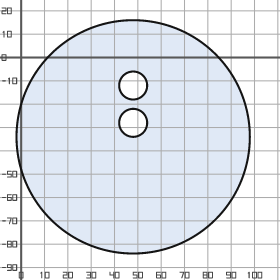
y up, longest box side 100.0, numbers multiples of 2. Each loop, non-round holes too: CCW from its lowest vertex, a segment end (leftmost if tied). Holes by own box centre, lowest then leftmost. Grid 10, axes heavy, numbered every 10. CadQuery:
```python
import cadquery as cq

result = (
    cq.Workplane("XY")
    .moveTo(48.0, -34.0)
    .circle(50.0)
    .moveTo(48.0, -28.0)
    .circle(6.0)
    .moveTo(48.0, -12.0)
    .circle(6.0)
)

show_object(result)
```